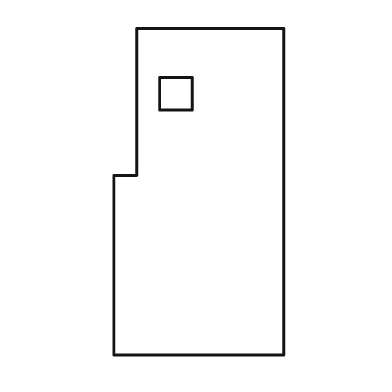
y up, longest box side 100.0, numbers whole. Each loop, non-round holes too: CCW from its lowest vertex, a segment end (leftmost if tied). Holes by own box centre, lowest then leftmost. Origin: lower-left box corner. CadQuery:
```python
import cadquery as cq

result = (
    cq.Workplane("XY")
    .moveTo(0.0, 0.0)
    .lineTo(52.0, 0.0)
    .lineTo(52.0, 100.0)
    .lineTo(7.0, 100.0)
    .lineTo(7.0, 55.0)
    .lineTo(0.0, 55.0)
    .close()
    .moveTo(14.0, 75.0)
    .lineTo(24.0, 75.0)
    .lineTo(24.0, 85.0)
    .lineTo(14.0, 85.0)
    .close()
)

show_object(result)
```